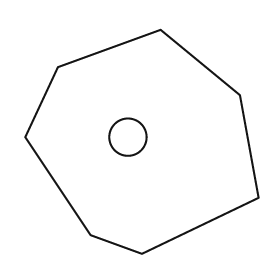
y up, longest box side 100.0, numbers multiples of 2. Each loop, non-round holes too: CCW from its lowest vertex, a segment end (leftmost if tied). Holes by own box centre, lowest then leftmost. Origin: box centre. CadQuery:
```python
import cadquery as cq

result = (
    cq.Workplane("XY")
    .moveTo(0.0, -48.0)
    .lineTo(50.0, -24.0)
    .lineTo(42.0, 20.0)
    .lineTo(8.0, 48.0)
    .lineTo(-36.0, 32.0)
    .lineTo(-50.0, 2.0)
    .lineTo(-22.0, -40.0)
    .close()
    .moveTo(-6.0, 2.0)
    .circle(8.0)
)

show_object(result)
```